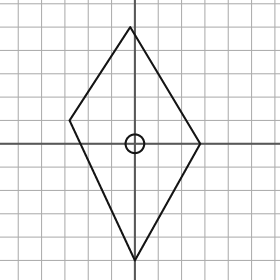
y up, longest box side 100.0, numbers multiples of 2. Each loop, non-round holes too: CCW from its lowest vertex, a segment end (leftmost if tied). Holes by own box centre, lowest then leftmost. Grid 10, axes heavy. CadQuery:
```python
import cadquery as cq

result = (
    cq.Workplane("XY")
    .moveTo(0.0, -50.0)
    .lineTo(28.0, 0.0)
    .lineTo(-2.0, 50.0)
    .lineTo(-28.0, 10.0)
    .close()
    .moveTo(0.0, 0.0)
    .circle(4.0)
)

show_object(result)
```